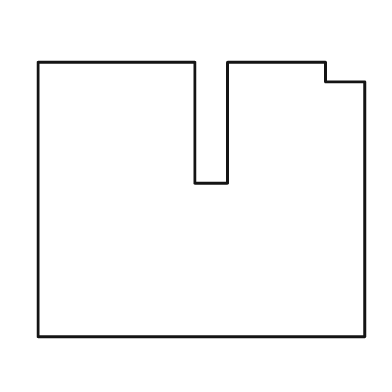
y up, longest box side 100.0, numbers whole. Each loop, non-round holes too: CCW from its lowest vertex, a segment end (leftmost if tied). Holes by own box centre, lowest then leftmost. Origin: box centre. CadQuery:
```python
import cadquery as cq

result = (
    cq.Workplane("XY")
    .moveTo(-50.0, -42.0)
    .lineTo(50.0, -42.0)
    .lineTo(50.0, 36.0)
    .lineTo(38.0, 36.0)
    .lineTo(38.0, 42.0)
    .lineTo(8.0, 42.0)
    .lineTo(8.0, 5.0)
    .lineTo(-2.0, 5.0)
    .lineTo(-2.0, 42.0)
    .lineTo(-50.0, 42.0)
    .close()
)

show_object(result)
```